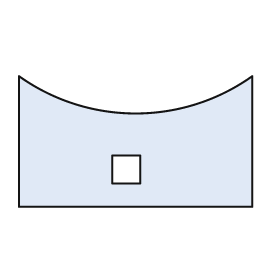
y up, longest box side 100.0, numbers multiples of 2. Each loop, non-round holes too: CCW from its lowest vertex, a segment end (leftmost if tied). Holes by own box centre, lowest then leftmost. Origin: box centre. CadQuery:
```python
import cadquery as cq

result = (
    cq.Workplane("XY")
    .moveTo(-50.0, -28.0)
    .lineTo(50.0, -28.0)
    .lineTo(50.0, 28.0)
    .threePointArc((0.0, 12.0), (-50.0, 28.0))
    .close()
    .moveTo(-10.0, -18.0)
    .lineTo(2.0, -18.0)
    .lineTo(2.0, -6.0)
    .lineTo(-10.0, -6.0)
    .close()
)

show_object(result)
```